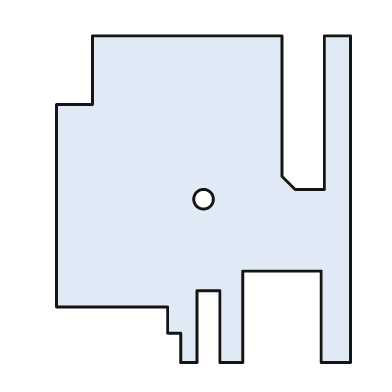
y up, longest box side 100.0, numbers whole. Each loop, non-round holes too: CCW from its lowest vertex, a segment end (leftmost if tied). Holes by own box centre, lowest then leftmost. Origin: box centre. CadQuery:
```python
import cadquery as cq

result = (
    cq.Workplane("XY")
    .moveTo(-7.0, -50.0)
    .lineTo(-2.0, -50.0)
    .lineTo(-2.0, -28.0)
    .lineTo(5.0, -28.0)
    .lineTo(5.0, -50.0)
    .lineTo(12.0, -50.0)
    .lineTo(12.0, -22.0)
    .lineTo(36.0, -22.0)
    .lineTo(36.0, -50.0)
    .lineTo(45.0, -50.0)
    .lineTo(45.0, 50.0)
    .lineTo(37.0, 50.0)
    .lineTo(37.0, 3.0)
    .lineTo(28.0, 3.0)
    .lineTo(24.0, 7.0)
    .lineTo(24.0, 50.0)
    .lineTo(-34.0, 50.0)
    .lineTo(-34.0, 29.0)
    .lineTo(-45.0, 29.0)
    .lineTo(-45.0, -33.0)
    .lineTo(-11.0, -33.0)
    .lineTo(-11.0, -41.0)
    .lineTo(-7.0, -41.0)
    .close()
    .moveTo(0.0, 0.0)
    .circle(3.0)
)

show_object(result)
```